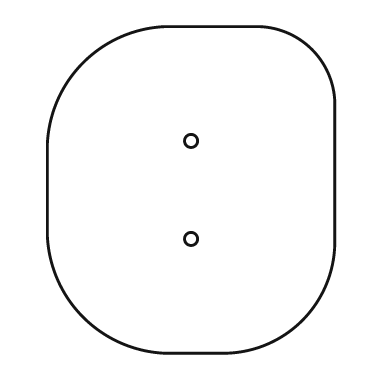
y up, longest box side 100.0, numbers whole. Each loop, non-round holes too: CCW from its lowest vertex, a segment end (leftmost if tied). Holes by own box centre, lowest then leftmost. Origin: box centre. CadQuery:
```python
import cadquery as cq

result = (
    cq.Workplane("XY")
    .moveTo(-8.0, -50.0)
    .lineTo(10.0, -50.0)
    .threePointArc((34.0, -40.0), (44.0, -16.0))
    .lineTo(44.0, 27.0)
    .threePointArc((37.0, 43.0), (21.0, 50.0))
    .lineTo(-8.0, 50.0)
    .threePointArc((-33.0, 39.0), (-44.0, 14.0))
    .lineTo(-44.0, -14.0)
    .threePointArc((-33.0, -39.0), (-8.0, -50.0))
    .close()
    .moveTo(0.0, -15.0)
    .circle(2.0)
    .moveTo(0.0, 15.0)
    .circle(2.0)
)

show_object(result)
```